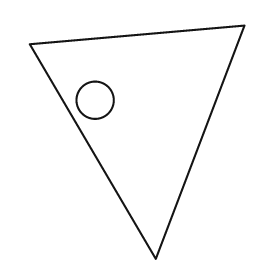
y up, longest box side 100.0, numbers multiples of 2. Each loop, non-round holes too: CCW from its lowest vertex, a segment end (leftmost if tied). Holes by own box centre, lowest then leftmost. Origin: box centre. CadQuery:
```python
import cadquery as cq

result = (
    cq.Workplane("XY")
    .moveTo(8.0, -50.0)
    .lineTo(46.0, 50.0)
    .lineTo(-46.0, 42.0)
    .close()
    .moveTo(-18.0, 18.0)
    .circle(8.0)
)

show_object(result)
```